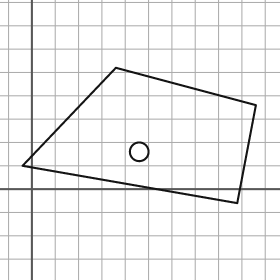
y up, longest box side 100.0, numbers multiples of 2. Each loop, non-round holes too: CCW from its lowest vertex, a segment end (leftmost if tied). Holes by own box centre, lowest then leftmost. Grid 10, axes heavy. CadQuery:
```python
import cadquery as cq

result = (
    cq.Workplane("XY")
    .moveTo(88.0, -6.0)
    .lineTo(96.0, 36.0)
    .lineTo(36.0, 52.0)
    .lineTo(-4.0, 10.0)
    .close()
    .moveTo(46.0, 16.0)
    .circle(4.0)
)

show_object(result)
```